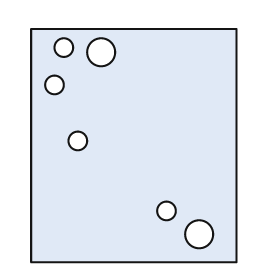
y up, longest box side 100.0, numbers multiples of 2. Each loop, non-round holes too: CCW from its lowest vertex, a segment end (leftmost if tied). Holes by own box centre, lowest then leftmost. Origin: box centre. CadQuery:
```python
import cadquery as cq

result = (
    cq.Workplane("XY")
    .moveTo(-44.0, -50.0)
    .lineTo(44.0, -50.0)
    .lineTo(44.0, 50.0)
    .lineTo(-44.0, 50.0)
    .close()
    .moveTo(28.0, -38.0)
    .circle(6.0)
    .moveTo(14.0, -28.0)
    .circle(4.0)
    .moveTo(-24.0, 2.0)
    .circle(4.0)
    .moveTo(-34.0, 26.0)
    .circle(4.0)
    .moveTo(-14.0, 40.0)
    .circle(6.0)
    .moveTo(-30.0, 42.0)
    .circle(4.0)
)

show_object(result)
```